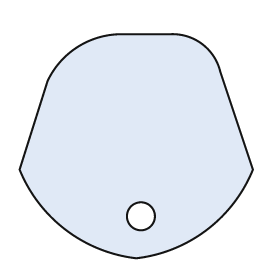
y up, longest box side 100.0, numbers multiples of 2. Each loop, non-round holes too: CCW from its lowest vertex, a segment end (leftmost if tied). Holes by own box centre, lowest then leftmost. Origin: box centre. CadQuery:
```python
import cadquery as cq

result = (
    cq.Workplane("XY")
    .moveTo(0.0, -48.0)
    .threePointArc((30.0, -36.0), (50.0, -10.0))
    .lineTo(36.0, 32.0)
    .threePointArc((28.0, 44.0), (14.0, 48.0))
    .lineTo(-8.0, 48.0)
    .threePointArc((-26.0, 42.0), (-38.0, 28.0))
    .lineTo(-50.0, -10.0)
    .threePointArc((-30.0, -36.0), (0.0, -48.0))
    .close()
    .moveTo(2.0, -30.0)
    .circle(6.0)
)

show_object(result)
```